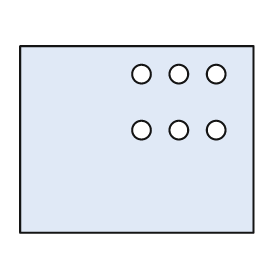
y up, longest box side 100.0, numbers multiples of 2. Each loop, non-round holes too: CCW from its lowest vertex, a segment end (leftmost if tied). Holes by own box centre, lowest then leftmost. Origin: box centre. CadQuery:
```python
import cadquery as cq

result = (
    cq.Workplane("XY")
    .moveTo(-50.0, -40.0)
    .lineTo(50.0, -40.0)
    .lineTo(50.0, 40.0)
    .lineTo(-50.0, 40.0)
    .close()
    .moveTo(2.0, 4.0)
    .circle(4.0)
    .moveTo(18.0, 4.0)
    .circle(4.0)
    .moveTo(34.0, 4.0)
    .circle(4.0)
    .moveTo(2.0, 28.0)
    .circle(4.0)
    .moveTo(18.0, 28.0)
    .circle(4.0)
    .moveTo(34.0, 28.0)
    .circle(4.0)
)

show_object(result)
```